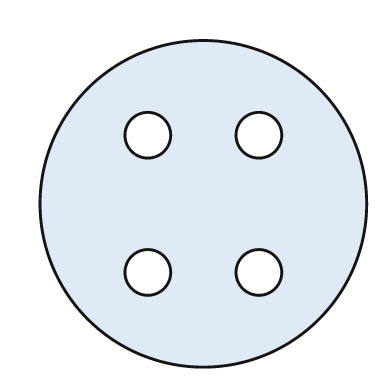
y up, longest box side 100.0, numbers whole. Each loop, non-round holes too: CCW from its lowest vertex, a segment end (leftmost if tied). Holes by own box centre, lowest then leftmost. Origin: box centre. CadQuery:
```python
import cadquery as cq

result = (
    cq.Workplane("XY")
    .moveTo(0.0, 0.0)
    .circle(50.0)
    .moveTo(-17.0, -21.0)
    .circle(7.0)
    .moveTo(17.0, -21.0)
    .circle(7.0)
    .moveTo(-17.0, 21.0)
    .circle(7.0)
    .moveTo(17.0, 21.0)
    .circle(7.0)
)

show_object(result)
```